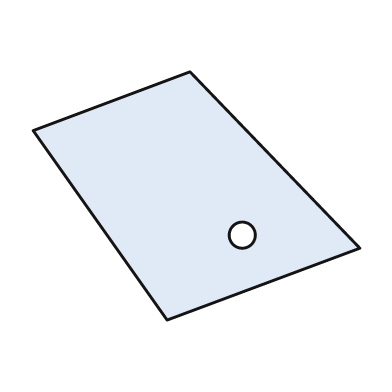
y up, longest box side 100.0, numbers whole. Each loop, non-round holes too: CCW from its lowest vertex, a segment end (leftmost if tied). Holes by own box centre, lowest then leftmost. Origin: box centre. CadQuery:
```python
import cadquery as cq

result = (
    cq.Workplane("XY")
    .moveTo(-9.0, -38.0)
    .lineTo(50.0, -16.0)
    .lineTo(-2.0, 38.0)
    .lineTo(-50.0, 20.0)
    .close()
    .moveTo(14.0, -12.0)
    .circle(4.0)
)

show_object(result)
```